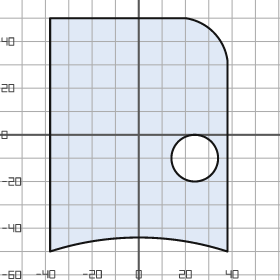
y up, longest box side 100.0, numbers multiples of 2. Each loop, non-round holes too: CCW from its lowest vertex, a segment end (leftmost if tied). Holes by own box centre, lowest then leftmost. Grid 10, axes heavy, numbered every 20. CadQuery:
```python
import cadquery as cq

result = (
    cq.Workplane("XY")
    .moveTo(-38.0, -50.0)
    .threePointArc((0.0, -44.0), (38.0, -50.0))
    .lineTo(38.0, 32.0)
    .threePointArc((32.0, 44.0), (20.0, 50.0))
    .lineTo(-38.0, 50.0)
    .close()
    .moveTo(24.0, -10.0)
    .circle(10.0)
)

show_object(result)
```